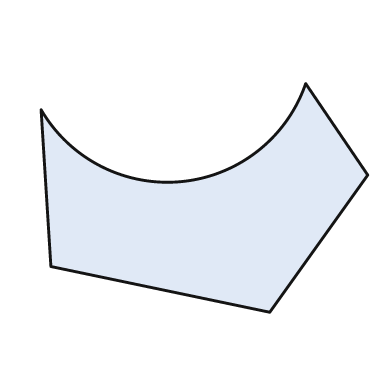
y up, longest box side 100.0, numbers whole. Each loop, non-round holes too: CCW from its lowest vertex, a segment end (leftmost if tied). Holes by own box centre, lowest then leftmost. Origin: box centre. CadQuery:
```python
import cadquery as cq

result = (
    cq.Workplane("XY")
    .moveTo(20.0, -35.0)
    .lineTo(50.0, 7.0)
    .lineTo(31.0, 35.0)
    .threePointArc((-7.0, 5.0), (-50.0, 27.0))
    .lineTo(-47.0, -21.0)
    .close()
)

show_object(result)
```